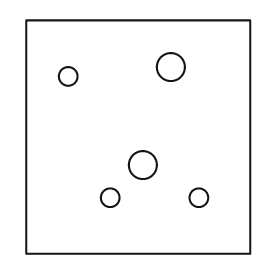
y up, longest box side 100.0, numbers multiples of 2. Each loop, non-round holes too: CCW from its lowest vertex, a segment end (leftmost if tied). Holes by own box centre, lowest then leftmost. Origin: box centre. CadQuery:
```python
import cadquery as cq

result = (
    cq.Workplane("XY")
    .moveTo(-48.0, -50.0)
    .lineTo(48.0, -50.0)
    .lineTo(48.0, 50.0)
    .lineTo(-48.0, 50.0)
    .close()
    .moveTo(-12.0, -26.0)
    .circle(4.0)
    .moveTo(26.0, -26.0)
    .circle(4.0)
    .moveTo(2.0, -12.0)
    .circle(6.0)
    .moveTo(-30.0, 26.0)
    .circle(4.0)
    .moveTo(14.0, 30.0)
    .circle(6.0)
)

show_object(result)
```